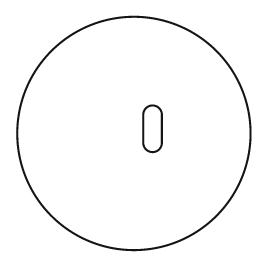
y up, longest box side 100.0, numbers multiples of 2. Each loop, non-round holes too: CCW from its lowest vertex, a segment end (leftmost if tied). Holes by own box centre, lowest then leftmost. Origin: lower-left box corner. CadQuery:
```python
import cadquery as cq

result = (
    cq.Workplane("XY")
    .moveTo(50.0, 50.0)
    .circle(50.0)
    .moveTo(54.0, 46.0)
    .threePointArc((58.0, 42.0), (62.0, 46.0))
    .lineTo(62.0, 58.0)
    .threePointArc((58.0, 62.0), (54.0, 58.0))
    .close()
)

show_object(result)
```